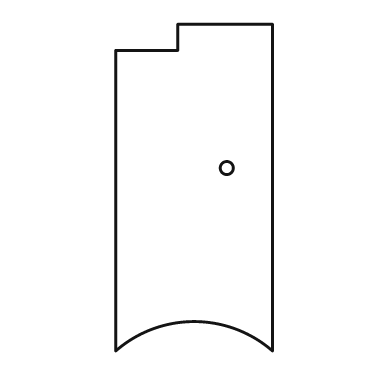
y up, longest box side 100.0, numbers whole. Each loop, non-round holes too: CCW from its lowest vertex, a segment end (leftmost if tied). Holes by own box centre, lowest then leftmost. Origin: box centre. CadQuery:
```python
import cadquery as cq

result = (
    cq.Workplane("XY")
    .moveTo(-24.0, -50.0)
    .threePointArc((0.0, -41.0), (24.0, -50.0))
    .lineTo(24.0, 50.0)
    .lineTo(-5.0, 50.0)
    .lineTo(-5.0, 42.0)
    .lineTo(-24.0, 42.0)
    .close()
    .moveTo(10.0, 6.0)
    .circle(2.0)
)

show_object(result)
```